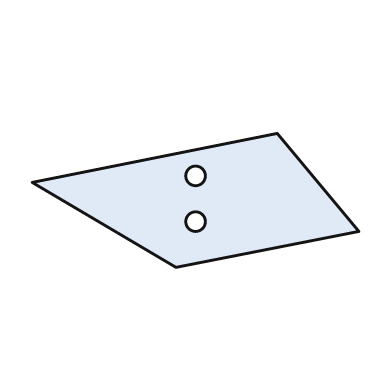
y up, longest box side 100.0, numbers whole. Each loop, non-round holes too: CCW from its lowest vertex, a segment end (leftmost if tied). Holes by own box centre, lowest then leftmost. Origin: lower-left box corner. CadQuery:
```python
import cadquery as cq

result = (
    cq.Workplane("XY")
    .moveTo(44.0, 0.0)
    .lineTo(100.0, 11.0)
    .lineTo(75.0, 41.0)
    .lineTo(0.0, 26.0)
    .close()
    .moveTo(50.0, 14.0)
    .circle(3.0)
    .moveTo(50.0, 28.0)
    .circle(3.0)
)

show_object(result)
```